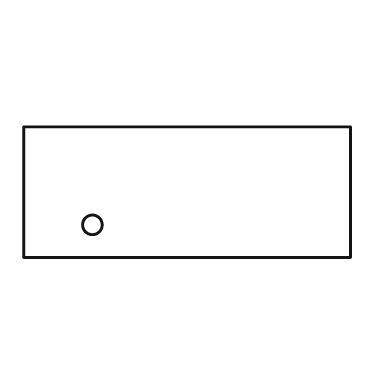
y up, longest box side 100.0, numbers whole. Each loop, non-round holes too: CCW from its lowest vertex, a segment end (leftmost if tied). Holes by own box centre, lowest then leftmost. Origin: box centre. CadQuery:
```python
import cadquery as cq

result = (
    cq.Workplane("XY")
    .moveTo(-50.0, -20.0)
    .lineTo(50.0, -20.0)
    .lineTo(50.0, 20.0)
    .lineTo(-50.0, 20.0)
    .close()
    .moveTo(-29.0, -10.0)
    .circle(3.0)
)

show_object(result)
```